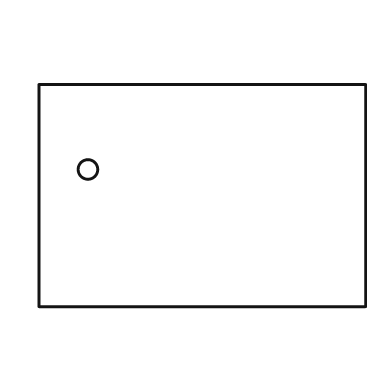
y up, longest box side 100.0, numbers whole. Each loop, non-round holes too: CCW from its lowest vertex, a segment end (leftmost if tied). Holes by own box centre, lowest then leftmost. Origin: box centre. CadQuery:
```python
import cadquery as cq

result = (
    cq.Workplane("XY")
    .moveTo(-50.0, -34.0)
    .lineTo(50.0, -34.0)
    .lineTo(50.0, 34.0)
    .lineTo(-50.0, 34.0)
    .close()
    .moveTo(-35.0, 8.0)
    .circle(3.0)
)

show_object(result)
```